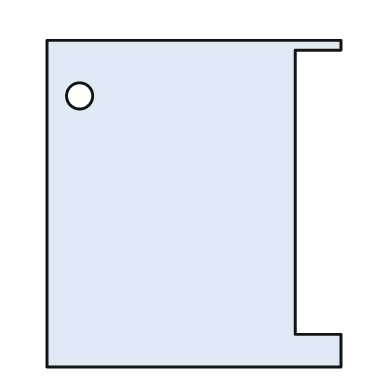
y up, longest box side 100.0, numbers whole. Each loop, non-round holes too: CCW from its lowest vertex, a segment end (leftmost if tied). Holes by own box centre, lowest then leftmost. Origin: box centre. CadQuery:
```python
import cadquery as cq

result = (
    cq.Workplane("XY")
    .moveTo(-45.0, -50.0)
    .lineTo(45.0, -50.0)
    .lineTo(45.0, -40.0)
    .lineTo(31.0, -40.0)
    .lineTo(31.0, 47.0)
    .lineTo(45.0, 47.0)
    .lineTo(45.0, 50.0)
    .lineTo(-45.0, 50.0)
    .close()
    .moveTo(-35.0, 33.0)
    .circle(4.0)
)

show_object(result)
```